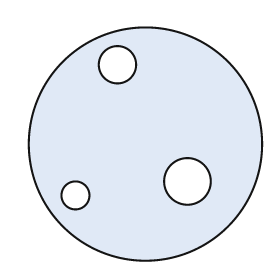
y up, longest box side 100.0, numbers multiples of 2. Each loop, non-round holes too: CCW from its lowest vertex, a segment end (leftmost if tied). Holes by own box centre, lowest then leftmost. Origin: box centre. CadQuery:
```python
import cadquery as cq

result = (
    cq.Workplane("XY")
    .moveTo(0.0, 0.0)
    .circle(50.0)
    .moveTo(-30.0, -22.0)
    .circle(6.0)
    .moveTo(18.0, -16.0)
    .circle(10.0)
    .moveTo(-12.0, 34.0)
    .circle(8.0)
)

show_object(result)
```